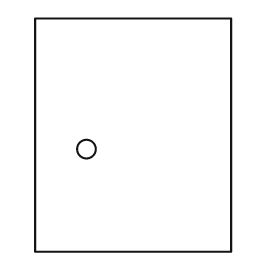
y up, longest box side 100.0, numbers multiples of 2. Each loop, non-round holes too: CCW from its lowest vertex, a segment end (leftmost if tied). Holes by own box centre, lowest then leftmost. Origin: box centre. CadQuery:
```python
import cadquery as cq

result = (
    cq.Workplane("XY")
    .moveTo(-42.0, -50.0)
    .lineTo(42.0, -50.0)
    .lineTo(42.0, 50.0)
    .lineTo(-42.0, 50.0)
    .close()
    .moveTo(-20.0, -6.0)
    .circle(4.0)
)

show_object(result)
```